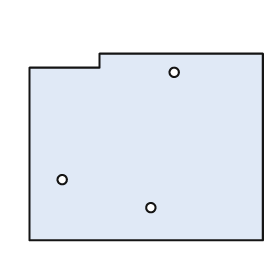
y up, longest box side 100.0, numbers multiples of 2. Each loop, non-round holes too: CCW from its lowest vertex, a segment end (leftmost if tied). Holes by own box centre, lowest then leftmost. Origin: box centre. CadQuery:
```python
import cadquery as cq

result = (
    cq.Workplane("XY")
    .moveTo(-50.0, -40.0)
    .lineTo(50.0, -40.0)
    .lineTo(50.0, 40.0)
    .lineTo(-20.0, 40.0)
    .lineTo(-20.0, 34.0)
    .lineTo(-50.0, 34.0)
    .close()
    .moveTo(2.0, -26.0)
    .circle(2.0)
    .moveTo(-36.0, -14.0)
    .circle(2.0)
    .moveTo(12.0, 32.0)
    .circle(2.0)
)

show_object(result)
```